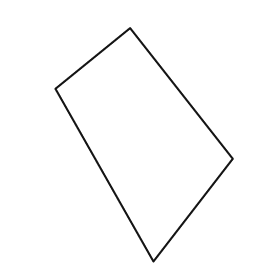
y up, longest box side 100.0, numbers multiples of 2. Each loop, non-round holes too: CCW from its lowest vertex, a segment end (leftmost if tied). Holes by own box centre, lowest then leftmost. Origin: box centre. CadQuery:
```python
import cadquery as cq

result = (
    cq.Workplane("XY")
    .moveTo(4.0, -50.0)
    .lineTo(38.0, -6.0)
    .lineTo(-6.0, 50.0)
    .lineTo(-38.0, 24.0)
    .close()
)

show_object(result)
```